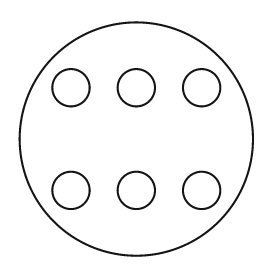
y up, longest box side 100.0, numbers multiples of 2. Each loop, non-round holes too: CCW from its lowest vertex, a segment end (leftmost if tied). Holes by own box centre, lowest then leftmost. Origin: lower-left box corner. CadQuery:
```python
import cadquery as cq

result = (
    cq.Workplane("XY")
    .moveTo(50.0, 50.0)
    .circle(50.0)
    .moveTo(22.0, 28.0)
    .circle(8.0)
    .moveTo(50.0, 28.0)
    .circle(8.0)
    .moveTo(78.0, 28.0)
    .circle(8.0)
    .moveTo(22.0, 72.0)
    .circle(8.0)
    .moveTo(50.0, 72.0)
    .circle(8.0)
    .moveTo(78.0, 72.0)
    .circle(8.0)
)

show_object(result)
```